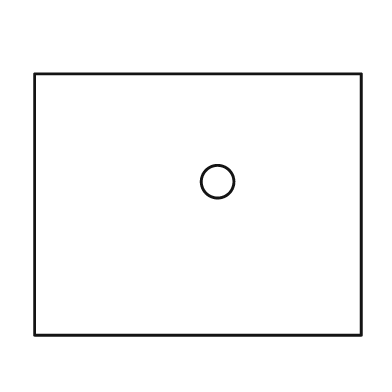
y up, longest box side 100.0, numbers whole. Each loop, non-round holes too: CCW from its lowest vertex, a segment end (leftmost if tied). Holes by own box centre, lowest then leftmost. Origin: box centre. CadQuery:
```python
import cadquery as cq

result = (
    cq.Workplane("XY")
    .moveTo(-50.0, -40.0)
    .lineTo(50.0, -40.0)
    .lineTo(50.0, 40.0)
    .lineTo(-50.0, 40.0)
    .close()
    .moveTo(6.0, 7.0)
    .circle(5.0)
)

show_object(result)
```